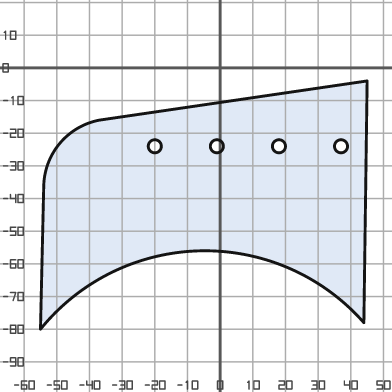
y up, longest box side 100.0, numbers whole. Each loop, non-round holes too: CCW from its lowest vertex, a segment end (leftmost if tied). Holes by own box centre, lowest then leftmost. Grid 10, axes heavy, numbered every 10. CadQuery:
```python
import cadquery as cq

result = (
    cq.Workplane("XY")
    .moveTo(-55.0, -80.0)
    .threePointArc((-6.0, -56.0), (44.0, -78.0))
    .lineTo(45.0, -4.0)
    .lineTo(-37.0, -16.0)
    .threePointArc((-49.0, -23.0), (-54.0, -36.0))
    .close()
    .moveTo(-20.0, -24.0)
    .circle(2.0)
    .moveTo(-1.0, -24.0)
    .circle(2.0)
    .moveTo(18.0, -24.0)
    .circle(2.0)
    .moveTo(37.0, -24.0)
    .circle(2.0)
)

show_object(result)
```